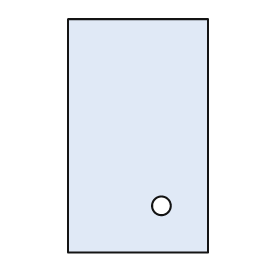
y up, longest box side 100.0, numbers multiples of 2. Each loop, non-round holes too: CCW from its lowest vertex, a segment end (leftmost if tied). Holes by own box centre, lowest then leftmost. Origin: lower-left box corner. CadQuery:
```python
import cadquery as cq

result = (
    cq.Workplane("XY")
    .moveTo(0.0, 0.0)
    .lineTo(60.0, 0.0)
    .lineTo(60.0, 100.0)
    .lineTo(0.0, 100.0)
    .close()
    .moveTo(40.0, 20.0)
    .circle(4.0)
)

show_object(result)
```